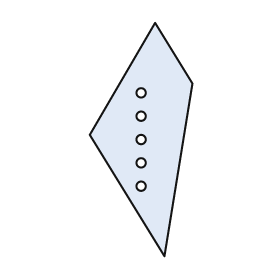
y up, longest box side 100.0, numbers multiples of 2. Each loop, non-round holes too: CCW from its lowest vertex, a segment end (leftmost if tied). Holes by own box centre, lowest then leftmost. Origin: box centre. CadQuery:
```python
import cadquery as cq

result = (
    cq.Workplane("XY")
    .moveTo(10.0, -50.0)
    .lineTo(22.0, 24.0)
    .lineTo(6.0, 50.0)
    .lineTo(-22.0, 2.0)
    .close()
    .moveTo(0.0, -20.0)
    .circle(2.0)
    .moveTo(0.0, -10.0)
    .circle(2.0)
    .moveTo(0.0, 0.0)
    .circle(2.0)
    .moveTo(0.0, 10.0)
    .circle(2.0)
    .moveTo(0.0, 20.0)
    .circle(2.0)
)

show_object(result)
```